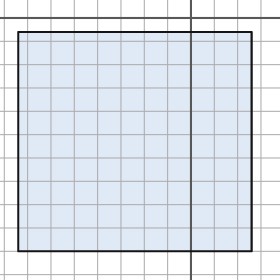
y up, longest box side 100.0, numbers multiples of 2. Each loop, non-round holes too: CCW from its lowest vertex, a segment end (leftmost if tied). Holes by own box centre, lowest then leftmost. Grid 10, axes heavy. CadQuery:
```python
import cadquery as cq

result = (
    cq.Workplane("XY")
    .moveTo(-74.0, -100.0)
    .lineTo(26.0, -100.0)
    .lineTo(26.0, -6.0)
    .lineTo(-74.0, -6.0)
    .close()
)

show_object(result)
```